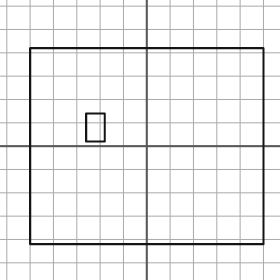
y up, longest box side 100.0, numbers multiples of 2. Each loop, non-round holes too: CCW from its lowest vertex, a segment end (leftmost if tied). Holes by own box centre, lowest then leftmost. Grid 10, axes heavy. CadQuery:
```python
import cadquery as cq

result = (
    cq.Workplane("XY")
    .moveTo(-50.0, -42.0)
    .lineTo(50.0, -42.0)
    .lineTo(50.0, 42.0)
    .lineTo(-50.0, 42.0)
    .close()
    .moveTo(-26.0, 2.0)
    .lineTo(-18.0, 2.0)
    .lineTo(-18.0, 14.0)
    .lineTo(-26.0, 14.0)
    .close()
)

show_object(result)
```